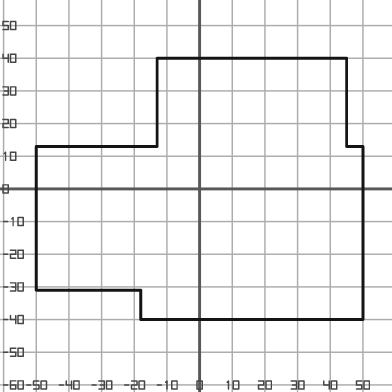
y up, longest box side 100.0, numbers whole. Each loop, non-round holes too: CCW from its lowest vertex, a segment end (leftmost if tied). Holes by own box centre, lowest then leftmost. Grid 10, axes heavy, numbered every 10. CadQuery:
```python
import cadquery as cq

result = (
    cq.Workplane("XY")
    .moveTo(-18.0, -40.0)
    .lineTo(50.0, -40.0)
    .lineTo(50.0, 13.0)
    .lineTo(45.0, 13.0)
    .lineTo(45.0, 40.0)
    .lineTo(-13.0, 40.0)
    .lineTo(-13.0, 13.0)
    .lineTo(-50.0, 13.0)
    .lineTo(-50.0, -31.0)
    .lineTo(-18.0, -31.0)
    .close()
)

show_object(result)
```